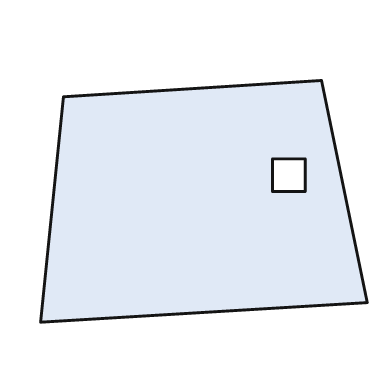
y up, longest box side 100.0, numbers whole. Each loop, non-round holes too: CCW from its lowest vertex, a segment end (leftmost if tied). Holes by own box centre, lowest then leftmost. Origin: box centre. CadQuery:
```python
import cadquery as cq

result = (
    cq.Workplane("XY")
    .moveTo(-50.0, -37.0)
    .lineTo(50.0, -31.0)
    .lineTo(36.0, 37.0)
    .lineTo(-43.0, 32.0)
    .close()
    .moveTo(21.0, 3.0)
    .lineTo(31.0, 3.0)
    .lineTo(31.0, 13.0)
    .lineTo(21.0, 13.0)
    .close()
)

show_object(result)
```